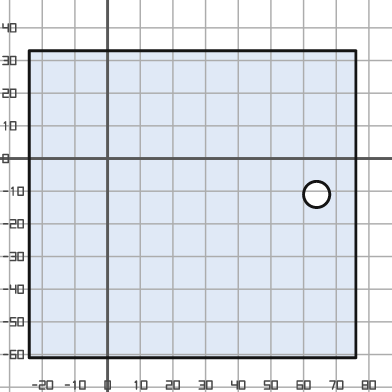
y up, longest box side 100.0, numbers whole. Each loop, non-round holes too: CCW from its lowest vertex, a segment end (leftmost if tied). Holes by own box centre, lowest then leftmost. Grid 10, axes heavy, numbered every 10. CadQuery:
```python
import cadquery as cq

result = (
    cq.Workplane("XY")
    .moveTo(-24.0, -61.0)
    .lineTo(76.0, -61.0)
    .lineTo(76.0, 33.0)
    .lineTo(-24.0, 33.0)
    .close()
    .moveTo(64.0, -11.0)
    .circle(4.0)
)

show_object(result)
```